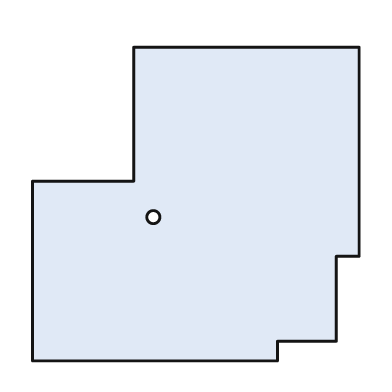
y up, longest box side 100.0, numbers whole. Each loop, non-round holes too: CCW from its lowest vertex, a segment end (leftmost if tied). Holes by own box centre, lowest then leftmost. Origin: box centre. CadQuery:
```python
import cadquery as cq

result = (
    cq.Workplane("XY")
    .moveTo(-50.0, -48.0)
    .lineTo(25.0, -48.0)
    .lineTo(25.0, -42.0)
    .lineTo(43.0, -42.0)
    .lineTo(43.0, -16.0)
    .lineTo(50.0, -16.0)
    .lineTo(50.0, 48.0)
    .lineTo(-19.0, 48.0)
    .lineTo(-19.0, 7.0)
    .lineTo(-50.0, 7.0)
    .close()
    .moveTo(-13.0, -4.0)
    .circle(2.0)
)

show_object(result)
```